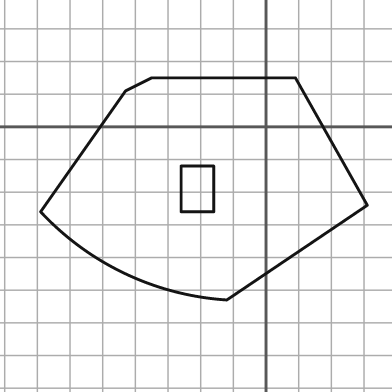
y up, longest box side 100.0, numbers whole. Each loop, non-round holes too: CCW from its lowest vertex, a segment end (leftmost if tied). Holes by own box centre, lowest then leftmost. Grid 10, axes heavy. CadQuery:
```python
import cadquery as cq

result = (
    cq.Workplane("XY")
    .moveTo(-12.0, -53.0)
    .lineTo(31.0, -24.0)
    .lineTo(9.0, 15.0)
    .lineTo(-35.0, 15.0)
    .lineTo(-43.0, 11.0)
    .lineTo(-69.0, -26.0)
    .threePointArc((-43.0, -45.0), (-12.0, -53.0))
    .close()
    .moveTo(-26.0, -26.0)
    .lineTo(-16.0, -26.0)
    .lineTo(-16.0, -12.0)
    .lineTo(-26.0, -12.0)
    .close()
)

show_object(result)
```